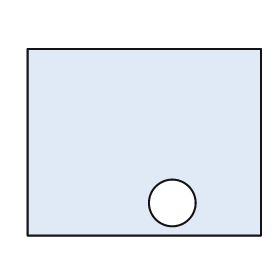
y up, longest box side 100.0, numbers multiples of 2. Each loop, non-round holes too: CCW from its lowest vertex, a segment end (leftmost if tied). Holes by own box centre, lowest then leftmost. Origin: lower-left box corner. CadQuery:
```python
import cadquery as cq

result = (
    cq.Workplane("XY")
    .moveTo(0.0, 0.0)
    .lineTo(100.0, 0.0)
    .lineTo(100.0, 80.0)
    .lineTo(0.0, 80.0)
    .close()
    .moveTo(62.0, 14.0)
    .circle(10.0)
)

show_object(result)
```